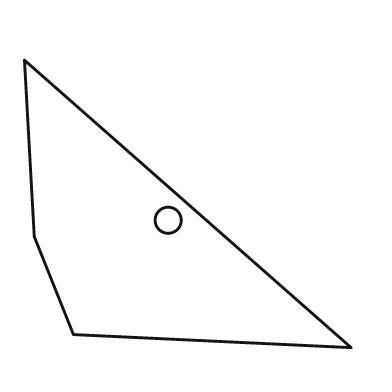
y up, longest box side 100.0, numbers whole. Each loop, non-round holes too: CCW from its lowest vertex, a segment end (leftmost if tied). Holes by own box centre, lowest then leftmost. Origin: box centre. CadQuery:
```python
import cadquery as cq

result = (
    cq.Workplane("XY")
    .moveTo(50.0, -44.0)
    .lineTo(-50.0, 44.0)
    .lineTo(-47.0, -10.0)
    .lineTo(-35.0, -40.0)
    .close()
    .moveTo(-6.0, -5.0)
    .circle(4.0)
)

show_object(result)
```